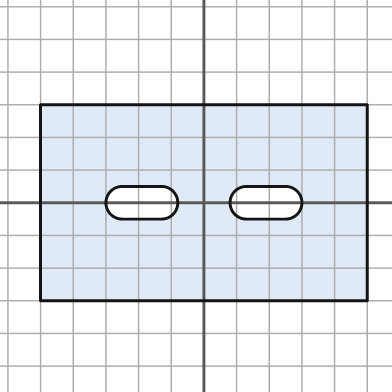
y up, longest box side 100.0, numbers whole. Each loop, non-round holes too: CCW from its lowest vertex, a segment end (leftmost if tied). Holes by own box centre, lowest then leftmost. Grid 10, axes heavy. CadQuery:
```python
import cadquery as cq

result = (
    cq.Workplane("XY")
    .moveTo(-50.0, -30.0)
    .lineTo(50.0, -30.0)
    .lineTo(50.0, 30.0)
    .lineTo(-50.0, 30.0)
    .close()
    .moveTo(-25.0, -5.0)
    .lineTo(-13.0, -5.0)
    .threePointArc((-8.0, 0.0), (-13.0, 5.0))
    .lineTo(-25.0, 5.0)
    .threePointArc((-30.0, 0.0), (-25.0, -5.0))
    .close()
    .moveTo(13.0, -5.0)
    .lineTo(25.0, -5.0)
    .threePointArc((30.0, 0.0), (25.0, 5.0))
    .lineTo(13.0, 5.0)
    .threePointArc((8.0, 0.0), (13.0, -5.0))
    .close()
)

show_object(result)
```